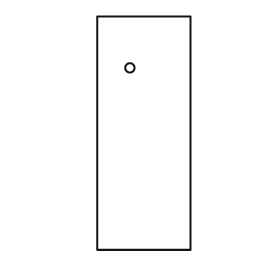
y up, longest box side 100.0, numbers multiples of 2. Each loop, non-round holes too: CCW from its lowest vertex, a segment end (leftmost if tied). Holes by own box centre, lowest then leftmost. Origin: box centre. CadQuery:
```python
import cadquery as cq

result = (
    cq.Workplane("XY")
    .moveTo(-20.0, -50.0)
    .lineTo(20.0, -50.0)
    .lineTo(20.0, 50.0)
    .lineTo(-20.0, 50.0)
    .close()
    .moveTo(-6.0, 28.0)
    .circle(2.0)
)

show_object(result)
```